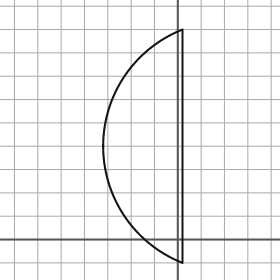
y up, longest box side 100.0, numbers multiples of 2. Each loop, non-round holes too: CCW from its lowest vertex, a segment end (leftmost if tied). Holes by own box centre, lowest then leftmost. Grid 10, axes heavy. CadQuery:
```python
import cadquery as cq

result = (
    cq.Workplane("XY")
    .moveTo(2.0, -10.0)
    .lineTo(2.0, 90.0)
    .threePointArc((-32.0, 40.0), (2.0, -10.0))
    .close()
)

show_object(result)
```